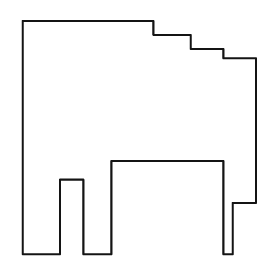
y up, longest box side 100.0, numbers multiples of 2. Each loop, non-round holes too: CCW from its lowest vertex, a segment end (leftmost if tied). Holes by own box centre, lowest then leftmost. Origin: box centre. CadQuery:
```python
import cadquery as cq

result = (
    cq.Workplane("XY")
    .moveTo(-50.0, -50.0)
    .lineTo(-34.0, -50.0)
    .lineTo(-34.0, -18.0)
    .lineTo(-24.0, -18.0)
    .lineTo(-24.0, -50.0)
    .lineTo(-12.0, -50.0)
    .lineTo(-12.0, -10.0)
    .lineTo(36.0, -10.0)
    .lineTo(36.0, -50.0)
    .lineTo(40.0, -50.0)
    .lineTo(40.0, -28.0)
    .lineTo(50.0, -28.0)
    .lineTo(50.0, 34.0)
    .lineTo(36.0, 34.0)
    .lineTo(36.0, 38.0)
    .lineTo(22.0, 38.0)
    .lineTo(22.0, 44.0)
    .lineTo(6.0, 44.0)
    .lineTo(6.0, 50.0)
    .lineTo(-50.0, 50.0)
    .close()
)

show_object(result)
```